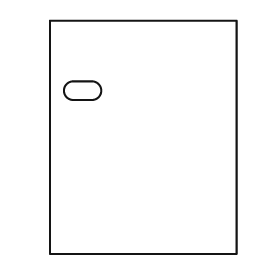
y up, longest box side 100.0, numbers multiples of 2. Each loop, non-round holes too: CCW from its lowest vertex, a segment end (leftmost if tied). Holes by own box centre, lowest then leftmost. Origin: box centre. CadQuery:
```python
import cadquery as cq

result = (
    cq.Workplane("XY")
    .moveTo(-40.0, -50.0)
    .lineTo(40.0, -50.0)
    .lineTo(40.0, 50.0)
    .lineTo(-40.0, 50.0)
    .close()
    .moveTo(-30.0, 16.0)
    .lineTo(-22.0, 16.0)
    .threePointArc((-18.0, 20.0), (-22.0, 24.0))
    .lineTo(-30.0, 24.0)
    .threePointArc((-34.0, 20.0), (-30.0, 16.0))
    .close()
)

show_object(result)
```